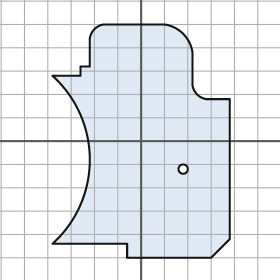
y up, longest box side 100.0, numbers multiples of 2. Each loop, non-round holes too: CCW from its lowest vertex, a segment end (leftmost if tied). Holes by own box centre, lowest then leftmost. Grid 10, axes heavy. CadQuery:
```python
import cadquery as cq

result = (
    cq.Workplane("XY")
    .moveTo(-6.0, -50.0)
    .lineTo(30.0, -50.0)
    .lineTo(38.0, -42.0)
    .lineTo(38.0, 18.0)
    .lineTo(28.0, 18.0)
    .threePointArc((24.0, 20.0), (22.0, 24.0))
    .lineTo(22.0, 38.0)
    .threePointArc((18.0, 46.0), (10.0, 50.0))
    .lineTo(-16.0, 50.0)
    .threePointArc((-20.0, 48.0), (-22.0, 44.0))
    .lineTo(-22.0, 32.0)
    .lineTo(-26.0, 32.0)
    .lineTo(-26.0, 28.0)
    .lineTo(-38.0, 28.0)
    .threePointArc((-22.0, -8.0), (-38.0, -44.0))
    .lineTo(-6.0, -44.0)
    .close()
    .moveTo(18.0, -12.0)
    .circle(2.0)
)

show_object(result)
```